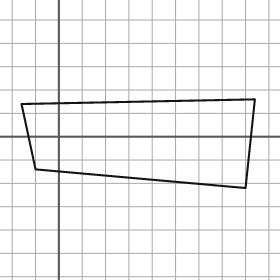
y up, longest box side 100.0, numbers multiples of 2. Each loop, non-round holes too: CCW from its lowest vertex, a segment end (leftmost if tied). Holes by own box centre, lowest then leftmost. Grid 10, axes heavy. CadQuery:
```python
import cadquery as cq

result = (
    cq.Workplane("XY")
    .moveTo(80.0, -22.0)
    .lineTo(84.0, 16.0)
    .lineTo(-16.0, 14.0)
    .lineTo(-10.0, -14.0)
    .close()
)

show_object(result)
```